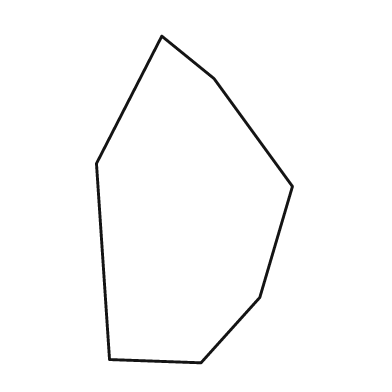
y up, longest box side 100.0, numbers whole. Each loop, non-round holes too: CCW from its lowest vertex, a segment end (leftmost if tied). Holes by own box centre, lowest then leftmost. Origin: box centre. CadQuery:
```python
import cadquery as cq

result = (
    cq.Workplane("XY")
    .moveTo(2.0, -50.0)
    .lineTo(20.0, -30.0)
    .lineTo(30.0, 4.0)
    .lineTo(6.0, 37.0)
    .lineTo(-10.0, 50.0)
    .lineTo(-30.0, 11.0)
    .lineTo(-26.0, -49.0)
    .close()
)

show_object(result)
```